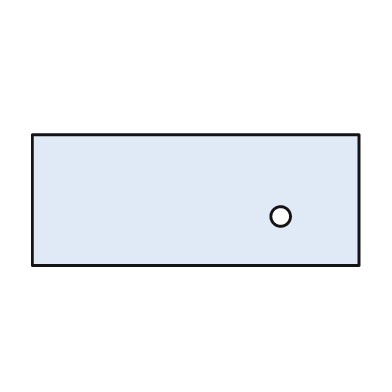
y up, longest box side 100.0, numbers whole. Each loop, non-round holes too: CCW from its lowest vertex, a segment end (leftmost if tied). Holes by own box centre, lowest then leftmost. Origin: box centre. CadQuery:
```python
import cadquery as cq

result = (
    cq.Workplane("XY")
    .moveTo(-50.0, -20.0)
    .lineTo(50.0, -20.0)
    .lineTo(50.0, 20.0)
    .lineTo(-50.0, 20.0)
    .close()
    .moveTo(26.0, -5.0)
    .circle(3.0)
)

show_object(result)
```